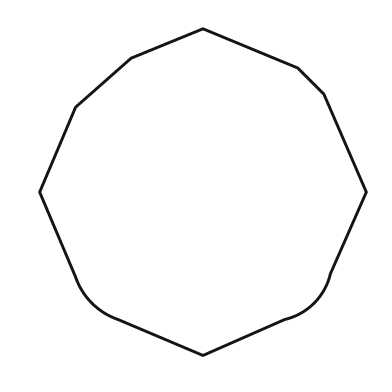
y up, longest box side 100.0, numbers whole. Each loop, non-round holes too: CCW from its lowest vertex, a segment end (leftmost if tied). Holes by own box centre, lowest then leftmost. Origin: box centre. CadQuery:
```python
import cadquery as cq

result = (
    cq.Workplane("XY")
    .moveTo(0.0, -50.0)
    .lineTo(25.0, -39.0)
    .threePointArc((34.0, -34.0), (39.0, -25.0))
    .lineTo(50.0, 0.0)
    .lineTo(37.0, 30.0)
    .lineTo(29.0, 38.0)
    .lineTo(0.0, 50.0)
    .lineTo(-22.0, 41.0)
    .lineTo(-39.0, 26.0)
    .lineTo(-50.0, 0.0)
    .lineTo(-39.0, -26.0)
    .threePointArc((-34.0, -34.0), (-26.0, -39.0))
    .close()
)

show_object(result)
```